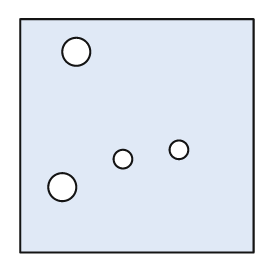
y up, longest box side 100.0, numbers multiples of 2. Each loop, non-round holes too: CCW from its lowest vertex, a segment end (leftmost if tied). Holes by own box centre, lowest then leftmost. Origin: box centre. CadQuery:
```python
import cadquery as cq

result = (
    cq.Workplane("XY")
    .moveTo(-50.0, -50.0)
    .lineTo(50.0, -50.0)
    .lineTo(50.0, 50.0)
    .lineTo(-50.0, 50.0)
    .close()
    .moveTo(-32.0, -22.0)
    .circle(6.0)
    .moveTo(-6.0, -10.0)
    .circle(4.0)
    .moveTo(18.0, -6.0)
    .circle(4.0)
    .moveTo(-26.0, 36.0)
    .circle(6.0)
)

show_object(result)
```